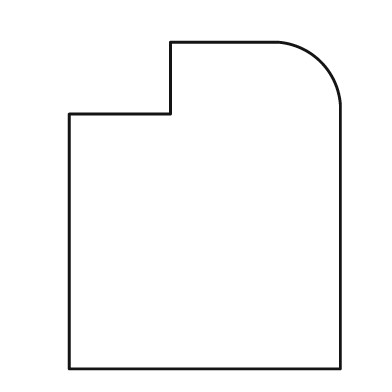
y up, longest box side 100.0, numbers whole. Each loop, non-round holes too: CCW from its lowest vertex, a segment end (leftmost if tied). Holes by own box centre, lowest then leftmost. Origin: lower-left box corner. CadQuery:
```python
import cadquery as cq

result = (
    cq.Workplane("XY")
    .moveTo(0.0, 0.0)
    .lineTo(83.0, 0.0)
    .lineTo(83.0, 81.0)
    .threePointArc((77.0, 94.0), (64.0, 100.0))
    .lineTo(31.0, 100.0)
    .lineTo(31.0, 78.0)
    .lineTo(0.0, 78.0)
    .close()
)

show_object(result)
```